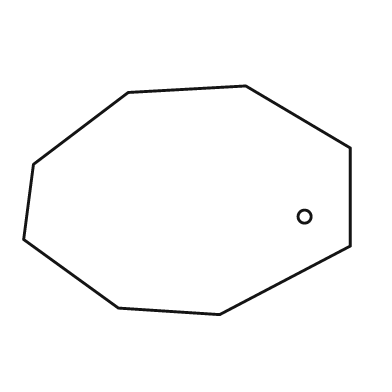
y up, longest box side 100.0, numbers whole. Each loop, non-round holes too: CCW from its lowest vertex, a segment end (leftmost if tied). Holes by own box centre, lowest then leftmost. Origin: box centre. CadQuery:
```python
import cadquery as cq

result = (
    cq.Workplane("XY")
    .moveTo(10.0, -35.0)
    .lineTo(50.0, -14.0)
    .lineTo(50.0, 16.0)
    .lineTo(18.0, 35.0)
    .lineTo(-18.0, 33.0)
    .lineTo(-47.0, 11.0)
    .lineTo(-50.0, -12.0)
    .lineTo(-21.0, -33.0)
    .close()
    .moveTo(36.0, -5.0)
    .circle(2.0)
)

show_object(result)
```